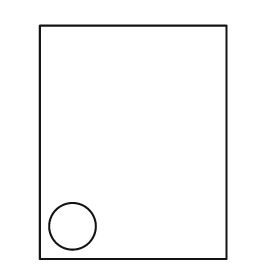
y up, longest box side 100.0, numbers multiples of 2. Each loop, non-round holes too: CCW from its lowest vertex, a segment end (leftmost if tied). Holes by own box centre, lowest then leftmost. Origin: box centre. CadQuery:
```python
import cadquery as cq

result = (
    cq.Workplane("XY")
    .moveTo(-40.0, -50.0)
    .lineTo(40.0, -50.0)
    .lineTo(40.0, 50.0)
    .lineTo(-40.0, 50.0)
    .close()
    .moveTo(-26.0, -36.0)
    .circle(10.0)
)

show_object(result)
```